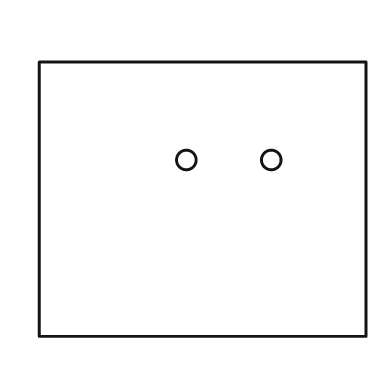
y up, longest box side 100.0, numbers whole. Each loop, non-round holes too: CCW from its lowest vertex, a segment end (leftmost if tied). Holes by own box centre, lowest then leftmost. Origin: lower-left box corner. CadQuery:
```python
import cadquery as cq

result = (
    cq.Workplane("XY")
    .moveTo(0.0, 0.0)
    .lineTo(100.0, 0.0)
    .lineTo(100.0, 84.0)
    .lineTo(0.0, 84.0)
    .close()
    .moveTo(45.0, 54.0)
    .circle(3.0)
    .moveTo(71.0, 54.0)
    .circle(3.0)
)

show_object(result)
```